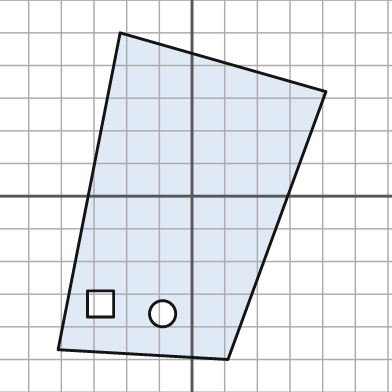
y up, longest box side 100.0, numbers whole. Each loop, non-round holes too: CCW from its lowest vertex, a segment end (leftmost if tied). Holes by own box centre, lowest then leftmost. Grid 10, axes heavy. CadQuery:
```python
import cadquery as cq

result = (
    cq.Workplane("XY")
    .moveTo(11.0, -50.0)
    .lineTo(41.0, 32.0)
    .lineTo(-22.0, 50.0)
    .lineTo(-41.0, -47.0)
    .close()
    .moveTo(-9.0, -36.0)
    .circle(4.0)
    .moveTo(-32.0, -37.0)
    .lineTo(-24.0, -37.0)
    .lineTo(-24.0, -29.0)
    .lineTo(-32.0, -29.0)
    .close()
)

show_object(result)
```